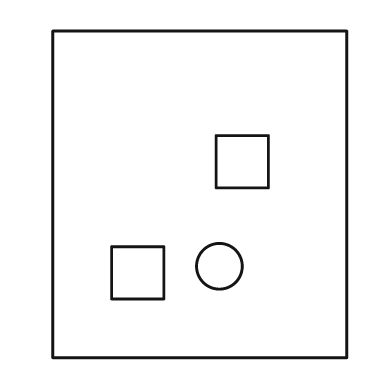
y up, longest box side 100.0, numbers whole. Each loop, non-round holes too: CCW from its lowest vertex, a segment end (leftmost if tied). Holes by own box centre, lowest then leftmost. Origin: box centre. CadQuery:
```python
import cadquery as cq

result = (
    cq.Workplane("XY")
    .moveTo(-45.0, -50.0)
    .lineTo(45.0, -50.0)
    .lineTo(45.0, 50.0)
    .lineTo(-45.0, 50.0)
    .close()
    .moveTo(-27.0, -32.0)
    .lineTo(-11.0, -32.0)
    .lineTo(-11.0, -16.0)
    .lineTo(-27.0, -16.0)
    .close()
    .moveTo(6.0, -22.0)
    .circle(7.0)
    .moveTo(5.0, 2.0)
    .lineTo(21.0, 2.0)
    .lineTo(21.0, 18.0)
    .lineTo(5.0, 18.0)
    .close()
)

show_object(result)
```